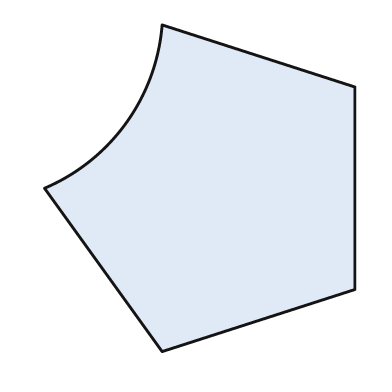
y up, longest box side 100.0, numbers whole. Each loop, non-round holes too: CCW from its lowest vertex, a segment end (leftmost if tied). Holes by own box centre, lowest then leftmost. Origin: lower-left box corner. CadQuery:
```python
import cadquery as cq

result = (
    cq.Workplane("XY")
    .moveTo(36.0, 0.0)
    .lineTo(95.0, 19.0)
    .lineTo(95.0, 81.0)
    .lineTo(36.0, 100.0)
    .threePointArc((25.0, 70.0), (0.0, 50.0))
    .close()
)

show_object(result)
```